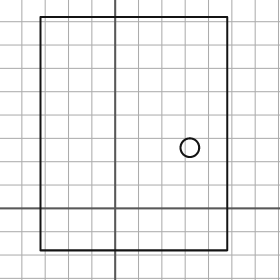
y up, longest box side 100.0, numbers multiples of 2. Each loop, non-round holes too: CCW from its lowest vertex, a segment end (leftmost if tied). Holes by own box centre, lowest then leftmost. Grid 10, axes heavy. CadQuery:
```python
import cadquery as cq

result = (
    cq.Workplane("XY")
    .moveTo(-32.0, -18.0)
    .lineTo(48.0, -18.0)
    .lineTo(48.0, 82.0)
    .lineTo(-32.0, 82.0)
    .close()
    .moveTo(32.0, 26.0)
    .circle(4.0)
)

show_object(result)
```